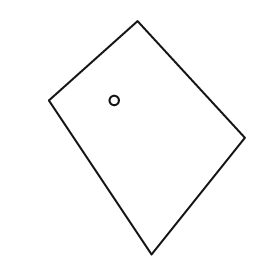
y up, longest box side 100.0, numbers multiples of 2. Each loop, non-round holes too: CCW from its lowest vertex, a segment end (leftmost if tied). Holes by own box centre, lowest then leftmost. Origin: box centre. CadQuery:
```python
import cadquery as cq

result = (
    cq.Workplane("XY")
    .moveTo(2.0, -50.0)
    .lineTo(42.0, 0.0)
    .lineTo(-4.0, 50.0)
    .lineTo(-42.0, 16.0)
    .close()
    .moveTo(-14.0, 16.0)
    .circle(2.0)
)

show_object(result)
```